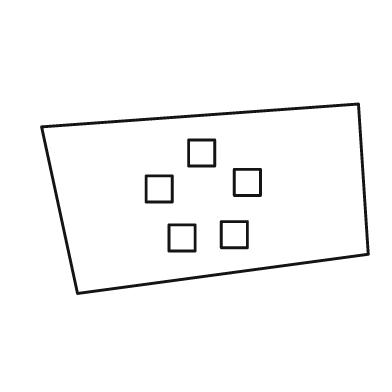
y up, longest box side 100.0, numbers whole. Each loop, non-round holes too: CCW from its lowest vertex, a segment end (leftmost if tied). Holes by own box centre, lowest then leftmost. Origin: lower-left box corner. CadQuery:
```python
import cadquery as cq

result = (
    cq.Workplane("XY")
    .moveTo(11.0, 0.0)
    .lineTo(100.0, 12.0)
    .lineTo(97.0, 58.0)
    .lineTo(0.0, 51.0)
    .close()
    .moveTo(39.0, 13.0)
    .lineTo(47.0, 13.0)
    .lineTo(47.0, 21.0)
    .lineTo(39.0, 21.0)
    .close()
    .moveTo(55.0, 14.0)
    .lineTo(63.0, 14.0)
    .lineTo(63.0, 22.0)
    .lineTo(55.0, 22.0)
    .close()
    .moveTo(32.0, 28.0)
    .lineTo(40.0, 28.0)
    .lineTo(40.0, 36.0)
    .lineTo(32.0, 36.0)
    .close()
    .moveTo(59.0, 30.0)
    .lineTo(67.0, 30.0)
    .lineTo(67.0, 38.0)
    .lineTo(59.0, 38.0)
    .close()
    .moveTo(45.0, 39.0)
    .lineTo(53.0, 39.0)
    .lineTo(53.0, 47.0)
    .lineTo(45.0, 47.0)
    .close()
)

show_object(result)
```